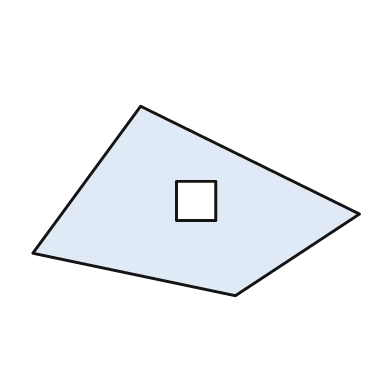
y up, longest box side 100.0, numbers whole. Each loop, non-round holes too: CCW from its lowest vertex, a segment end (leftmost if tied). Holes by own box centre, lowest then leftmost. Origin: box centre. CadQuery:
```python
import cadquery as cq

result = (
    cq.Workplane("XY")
    .moveTo(12.0, -29.0)
    .lineTo(50.0, -4.0)
    .lineTo(-17.0, 29.0)
    .lineTo(-50.0, -16.0)
    .close()
    .moveTo(-6.0, -6.0)
    .lineTo(6.0, -6.0)
    .lineTo(6.0, 6.0)
    .lineTo(-6.0, 6.0)
    .close()
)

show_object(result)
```